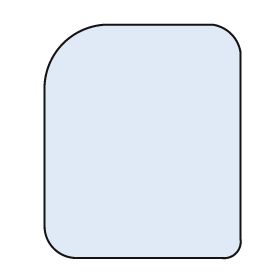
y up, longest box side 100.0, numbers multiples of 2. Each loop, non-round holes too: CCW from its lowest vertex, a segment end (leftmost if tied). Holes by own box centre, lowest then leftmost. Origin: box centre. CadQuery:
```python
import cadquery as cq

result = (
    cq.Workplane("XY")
    .moveTo(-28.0, -50.0)
    .lineTo(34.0, -50.0)
    .threePointArc((40.0, -48.0), (42.0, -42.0))
    .lineTo(42.0, 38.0)
    .threePointArc((38.0, 46.0), (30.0, 50.0))
    .lineTo(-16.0, 50.0)
    .threePointArc((-34.0, 42.0), (-42.0, 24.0))
    .lineTo(-42.0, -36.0)
    .threePointArc((-38.0, -46.0), (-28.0, -50.0))
    .close()
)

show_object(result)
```